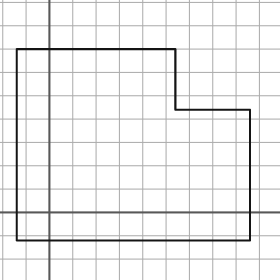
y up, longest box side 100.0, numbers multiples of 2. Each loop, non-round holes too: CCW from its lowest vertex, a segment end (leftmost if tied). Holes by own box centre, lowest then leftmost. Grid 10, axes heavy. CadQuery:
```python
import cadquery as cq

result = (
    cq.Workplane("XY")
    .moveTo(-14.0, -12.0)
    .lineTo(86.0, -12.0)
    .lineTo(86.0, 44.0)
    .lineTo(54.0, 44.0)
    .lineTo(54.0, 70.0)
    .lineTo(-14.0, 70.0)
    .close()
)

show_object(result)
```